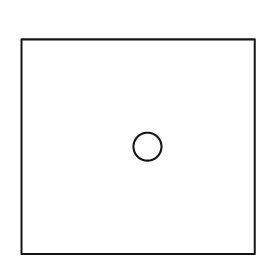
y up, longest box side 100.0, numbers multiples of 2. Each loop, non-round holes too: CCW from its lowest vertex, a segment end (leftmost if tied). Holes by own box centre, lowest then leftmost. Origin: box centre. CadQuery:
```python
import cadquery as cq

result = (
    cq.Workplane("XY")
    .moveTo(-50.0, -46.0)
    .lineTo(50.0, -46.0)
    .lineTo(50.0, 46.0)
    .lineTo(-50.0, 46.0)
    .close()
    .moveTo(4.0, 0.0)
    .circle(6.0)
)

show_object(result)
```